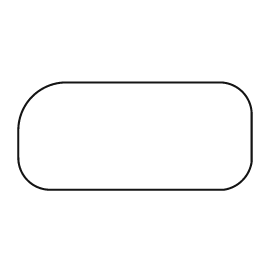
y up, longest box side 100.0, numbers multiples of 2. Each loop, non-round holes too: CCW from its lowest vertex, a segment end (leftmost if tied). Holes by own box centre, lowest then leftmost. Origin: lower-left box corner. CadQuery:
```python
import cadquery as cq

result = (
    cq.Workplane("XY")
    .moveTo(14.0, 0.0)
    .lineTo(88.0, 0.0)
    .threePointArc((96.0, 4.0), (100.0, 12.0))
    .lineTo(100.0, 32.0)
    .threePointArc((96.0, 42.0), (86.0, 46.0))
    .lineTo(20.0, 46.0)
    .threePointArc((6.0, 40.0), (0.0, 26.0))
    .lineTo(0.0, 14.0)
    .threePointArc((4.0, 4.0), (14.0, 0.0))
    .close()
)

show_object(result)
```